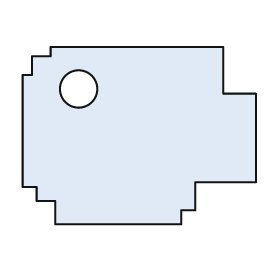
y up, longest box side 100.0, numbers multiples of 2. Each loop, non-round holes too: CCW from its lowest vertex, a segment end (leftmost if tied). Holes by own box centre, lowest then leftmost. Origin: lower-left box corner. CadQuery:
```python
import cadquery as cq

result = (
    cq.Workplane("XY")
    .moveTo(14.0, 0.0)
    .lineTo(68.0, 0.0)
    .lineTo(68.0, 6.0)
    .lineTo(74.0, 6.0)
    .lineTo(74.0, 18.0)
    .lineTo(100.0, 18.0)
    .lineTo(100.0, 56.0)
    .lineTo(86.0, 56.0)
    .lineTo(86.0, 76.0)
    .lineTo(12.0, 76.0)
    .lineTo(12.0, 72.0)
    .lineTo(4.0, 72.0)
    .lineTo(4.0, 64.0)
    .lineTo(0.0, 64.0)
    .lineTo(0.0, 16.0)
    .lineTo(6.0, 16.0)
    .lineTo(6.0, 10.0)
    .lineTo(14.0, 10.0)
    .close()
    .moveTo(24.0, 58.0)
    .circle(8.0)
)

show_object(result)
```